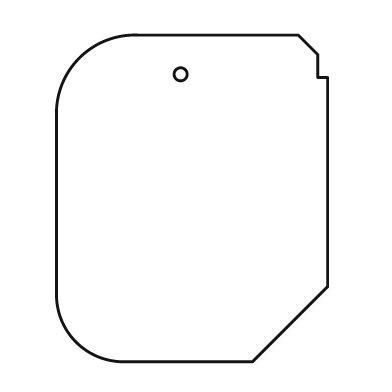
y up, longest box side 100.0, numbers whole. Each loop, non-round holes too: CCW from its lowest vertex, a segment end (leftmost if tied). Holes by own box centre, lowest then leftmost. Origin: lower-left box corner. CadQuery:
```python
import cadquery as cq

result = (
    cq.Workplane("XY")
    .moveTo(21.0, 0.0)
    .lineTo(60.0, 0.0)
    .lineTo(83.0, 23.0)
    .lineTo(83.0, 87.0)
    .lineTo(80.0, 87.0)
    .lineTo(80.0, 94.0)
    .lineTo(74.0, 100.0)
    .lineTo(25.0, 100.0)
    .threePointArc((7.0, 93.0), (0.0, 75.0))
    .lineTo(0.0, 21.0)
    .threePointArc((6.0, 6.0), (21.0, 0.0))
    .close()
    .moveTo(38.0, 88.0)
    .circle(2.0)
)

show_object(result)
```